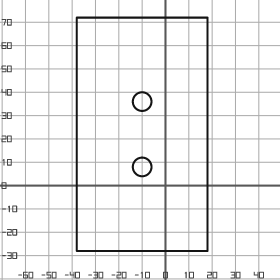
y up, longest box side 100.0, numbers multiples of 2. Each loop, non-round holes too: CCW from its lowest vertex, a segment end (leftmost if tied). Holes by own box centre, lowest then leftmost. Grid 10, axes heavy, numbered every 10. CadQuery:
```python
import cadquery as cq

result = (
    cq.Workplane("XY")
    .moveTo(-38.0, -28.0)
    .lineTo(18.0, -28.0)
    .lineTo(18.0, 72.0)
    .lineTo(-38.0, 72.0)
    .close()
    .moveTo(-10.0, 8.0)
    .circle(4.0)
    .moveTo(-10.0, 36.0)
    .circle(4.0)
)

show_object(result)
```